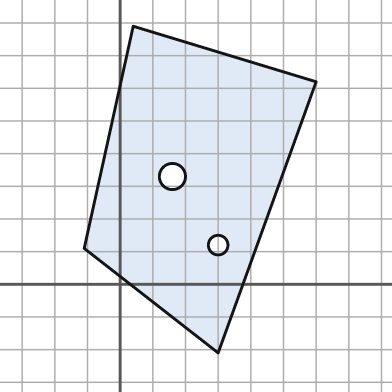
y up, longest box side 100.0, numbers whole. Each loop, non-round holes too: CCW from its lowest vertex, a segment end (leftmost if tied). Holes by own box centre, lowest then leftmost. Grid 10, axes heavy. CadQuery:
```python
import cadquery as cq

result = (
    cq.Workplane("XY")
    .moveTo(30.0, -21.0)
    .lineTo(60.0, 62.0)
    .lineTo(4.0, 79.0)
    .lineTo(-11.0, 11.0)
    .close()
    .moveTo(30.0, 12.0)
    .circle(3.0)
    .moveTo(16.0, 33.0)
    .circle(4.0)
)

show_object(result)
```